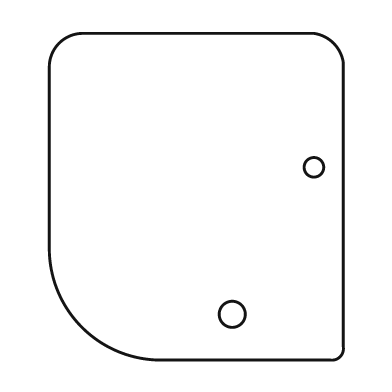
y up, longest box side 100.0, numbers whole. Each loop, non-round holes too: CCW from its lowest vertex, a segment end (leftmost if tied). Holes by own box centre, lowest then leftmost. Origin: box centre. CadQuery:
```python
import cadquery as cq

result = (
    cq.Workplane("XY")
    .moveTo(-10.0, -50.0)
    .lineTo(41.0, -50.0)
    .threePointArc((44.0, -49.0), (45.0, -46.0))
    .lineTo(45.0, 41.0)
    .threePointArc((42.0, 47.0), (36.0, 50.0))
    .lineTo(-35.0, 50.0)
    .threePointArc((-42.0, 47.0), (-45.0, 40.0))
    .lineTo(-45.0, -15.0)
    .threePointArc((-35.0, -40.0), (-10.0, -50.0))
    .close()
    .moveTo(11.0, -36.0)
    .circle(4.0)
    .moveTo(36.0, 9.0)
    .circle(3.0)
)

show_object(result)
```